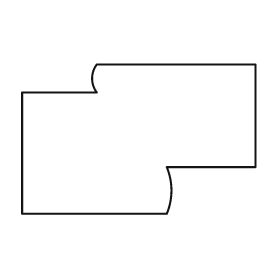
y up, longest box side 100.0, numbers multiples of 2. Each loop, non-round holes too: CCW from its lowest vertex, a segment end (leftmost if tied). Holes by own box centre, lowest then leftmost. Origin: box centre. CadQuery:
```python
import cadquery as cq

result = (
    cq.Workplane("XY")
    .moveTo(-50.0, -32.0)
    .lineTo(12.0, -32.0)
    .threePointArc((14.0, -22.0), (12.0, -12.0))
    .lineTo(50.0, -12.0)
    .lineTo(50.0, 32.0)
    .lineTo(-18.0, 32.0)
    .threePointArc((-20.0, 26.0), (-18.0, 20.0))
    .lineTo(-50.0, 20.0)
    .close()
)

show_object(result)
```